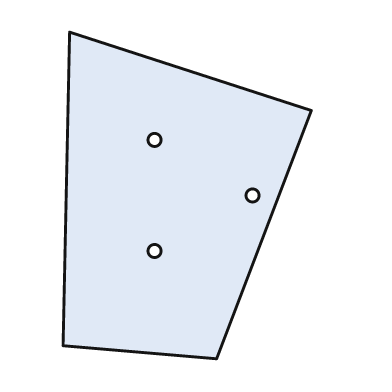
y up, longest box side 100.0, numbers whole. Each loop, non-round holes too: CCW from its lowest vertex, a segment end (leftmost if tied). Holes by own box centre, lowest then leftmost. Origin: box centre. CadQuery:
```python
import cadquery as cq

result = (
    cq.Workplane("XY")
    .moveTo(9.0, -50.0)
    .lineTo(38.0, 26.0)
    .lineTo(-36.0, 50.0)
    .lineTo(-38.0, -46.0)
    .close()
    .moveTo(-10.0, -17.0)
    .circle(2.0)
    .moveTo(20.0, 0.0)
    .circle(2.0)
    .moveTo(-10.0, 17.0)
    .circle(2.0)
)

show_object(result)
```